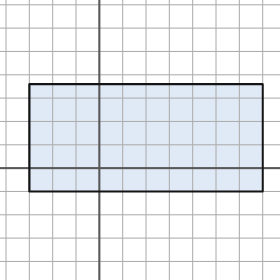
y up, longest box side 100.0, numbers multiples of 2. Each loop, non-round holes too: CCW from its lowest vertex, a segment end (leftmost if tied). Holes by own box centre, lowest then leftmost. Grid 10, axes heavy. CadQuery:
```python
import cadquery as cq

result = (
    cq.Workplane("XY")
    .moveTo(-30.0, -10.0)
    .lineTo(70.0, -10.0)
    .lineTo(70.0, 36.0)
    .lineTo(-30.0, 36.0)
    .close()
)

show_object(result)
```